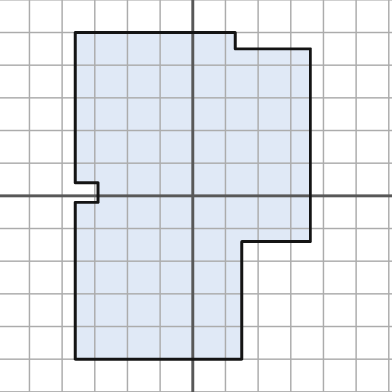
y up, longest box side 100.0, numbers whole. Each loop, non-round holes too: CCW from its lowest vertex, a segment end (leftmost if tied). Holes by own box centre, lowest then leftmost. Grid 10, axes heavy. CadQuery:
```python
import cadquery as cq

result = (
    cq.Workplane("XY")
    .moveTo(-36.0, -50.0)
    .lineTo(15.0, -50.0)
    .lineTo(15.0, -14.0)
    .lineTo(36.0, -14.0)
    .lineTo(36.0, 45.0)
    .lineTo(13.0, 45.0)
    .lineTo(13.0, 50.0)
    .lineTo(-36.0, 50.0)
    .lineTo(-36.0, 4.0)
    .lineTo(-29.0, 4.0)
    .lineTo(-29.0, -2.0)
    .lineTo(-36.0, -2.0)
    .close()
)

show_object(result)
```